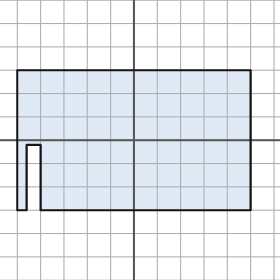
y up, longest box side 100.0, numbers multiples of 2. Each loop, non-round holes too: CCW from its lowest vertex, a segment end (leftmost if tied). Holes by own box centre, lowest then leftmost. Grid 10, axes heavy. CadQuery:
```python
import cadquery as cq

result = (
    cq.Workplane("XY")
    .moveTo(-50.0, -30.0)
    .lineTo(-46.0, -30.0)
    .lineTo(-46.0, -2.0)
    .lineTo(-40.0, -2.0)
    .lineTo(-40.0, -30.0)
    .lineTo(50.0, -30.0)
    .lineTo(50.0, 30.0)
    .lineTo(-50.0, 30.0)
    .close()
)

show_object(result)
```